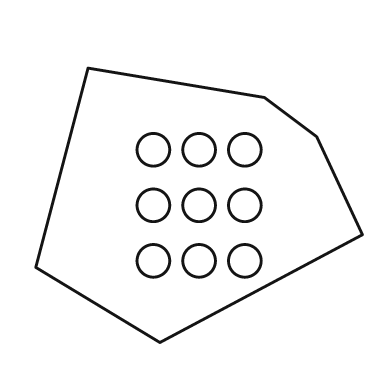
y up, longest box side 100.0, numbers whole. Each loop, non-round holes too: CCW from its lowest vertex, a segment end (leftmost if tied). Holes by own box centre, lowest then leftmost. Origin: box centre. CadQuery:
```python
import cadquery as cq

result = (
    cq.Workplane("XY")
    .moveTo(-12.0, -42.0)
    .lineTo(50.0, -9.0)
    .lineTo(36.0, 21.0)
    .lineTo(20.0, 33.0)
    .lineTo(-34.0, 42.0)
    .lineTo(-50.0, -19.0)
    .close()
    .moveTo(-14.0, -17.0)
    .circle(5.0)
    .moveTo(0.0, -17.0)
    .circle(5.0)
    .moveTo(14.0, -17.0)
    .circle(5.0)
    .moveTo(-14.0, 0.0)
    .circle(5.0)
    .moveTo(0.0, 0.0)
    .circle(5.0)
    .moveTo(14.0, 0.0)
    .circle(5.0)
    .moveTo(-14.0, 17.0)
    .circle(5.0)
    .moveTo(0.0, 17.0)
    .circle(5.0)
    .moveTo(14.0, 17.0)
    .circle(5.0)
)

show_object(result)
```